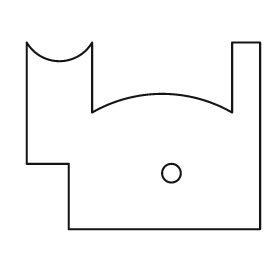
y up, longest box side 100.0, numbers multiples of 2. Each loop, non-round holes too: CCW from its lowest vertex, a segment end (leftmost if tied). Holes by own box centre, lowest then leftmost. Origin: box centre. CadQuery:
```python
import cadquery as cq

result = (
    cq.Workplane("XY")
    .moveTo(-32.0, -40.0)
    .lineTo(50.0, -40.0)
    .lineTo(50.0, 40.0)
    .lineTo(38.0, 40.0)
    .lineTo(38.0, 10.0)
    .threePointArc((8.0, 18.0), (-22.0, 10.0))
    .lineTo(-22.0, 40.0)
    .threePointArc((-36.0, 32.0), (-50.0, 40.0))
    .lineTo(-50.0, -12.0)
    .lineTo(-32.0, -12.0)
    .close()
    .moveTo(12.0, -16.0)
    .circle(4.0)
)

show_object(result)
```